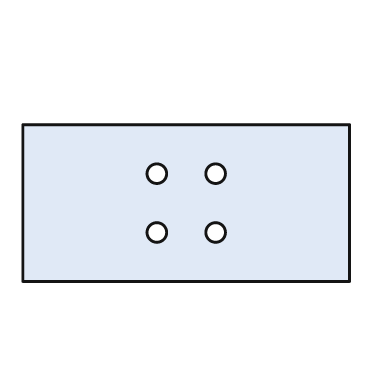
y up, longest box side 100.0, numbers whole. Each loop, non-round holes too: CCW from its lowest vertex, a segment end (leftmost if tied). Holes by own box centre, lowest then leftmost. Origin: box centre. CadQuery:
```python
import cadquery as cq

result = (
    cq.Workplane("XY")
    .moveTo(-50.0, -24.0)
    .lineTo(50.0, -24.0)
    .lineTo(50.0, 24.0)
    .lineTo(-50.0, 24.0)
    .close()
    .moveTo(-9.0, -9.0)
    .circle(3.0)
    .moveTo(9.0, -9.0)
    .circle(3.0)
    .moveTo(-9.0, 9.0)
    .circle(3.0)
    .moveTo(9.0, 9.0)
    .circle(3.0)
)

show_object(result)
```